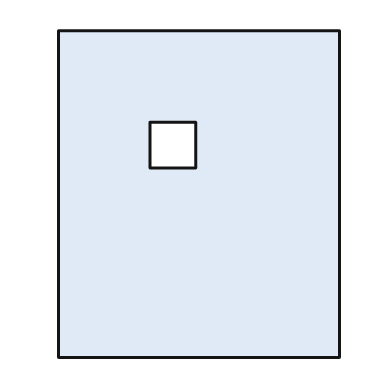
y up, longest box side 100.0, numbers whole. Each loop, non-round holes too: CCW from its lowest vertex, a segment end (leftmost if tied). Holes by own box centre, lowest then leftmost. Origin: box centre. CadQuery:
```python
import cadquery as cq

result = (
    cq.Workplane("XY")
    .moveTo(-43.0, -50.0)
    .lineTo(43.0, -50.0)
    .lineTo(43.0, 50.0)
    .lineTo(-43.0, 50.0)
    .close()
    .moveTo(-15.0, 8.0)
    .lineTo(-1.0, 8.0)
    .lineTo(-1.0, 22.0)
    .lineTo(-15.0, 22.0)
    .close()
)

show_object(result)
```